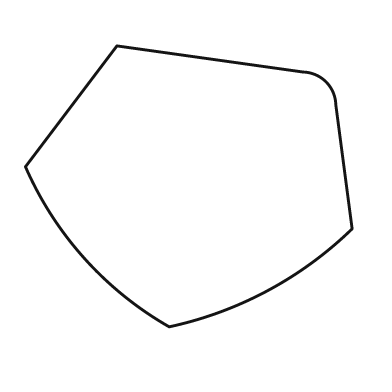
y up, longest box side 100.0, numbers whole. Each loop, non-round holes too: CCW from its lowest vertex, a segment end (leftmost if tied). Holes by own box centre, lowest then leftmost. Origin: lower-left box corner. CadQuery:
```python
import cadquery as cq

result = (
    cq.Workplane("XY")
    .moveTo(44.0, 0.0)
    .threePointArc((74.0, 11.0), (100.0, 30.0))
    .lineTo(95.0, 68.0)
    .threePointArc((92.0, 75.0), (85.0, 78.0))
    .lineTo(28.0, 86.0)
    .lineTo(0.0, 49.0)
    .threePointArc((18.0, 21.0), (44.0, 0.0))
    .close()
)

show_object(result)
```